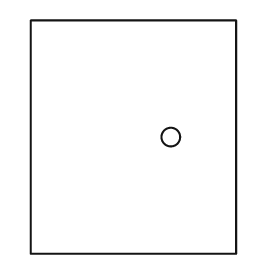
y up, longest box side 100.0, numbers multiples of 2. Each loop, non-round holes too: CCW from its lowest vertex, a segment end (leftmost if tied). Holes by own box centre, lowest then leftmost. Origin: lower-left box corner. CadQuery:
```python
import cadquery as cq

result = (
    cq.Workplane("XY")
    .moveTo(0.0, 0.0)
    .lineTo(88.0, 0.0)
    .lineTo(88.0, 100.0)
    .lineTo(0.0, 100.0)
    .close()
    .moveTo(60.0, 50.0)
    .circle(4.0)
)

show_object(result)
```